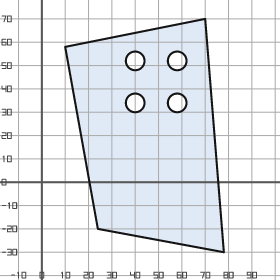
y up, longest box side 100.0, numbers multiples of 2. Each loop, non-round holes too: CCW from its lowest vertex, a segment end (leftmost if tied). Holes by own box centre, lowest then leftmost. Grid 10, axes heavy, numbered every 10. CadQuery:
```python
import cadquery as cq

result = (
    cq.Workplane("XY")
    .moveTo(78.0, -30.0)
    .lineTo(70.0, 70.0)
    .lineTo(10.0, 58.0)
    .lineTo(24.0, -20.0)
    .close()
    .moveTo(40.0, 34.0)
    .circle(4.0)
    .moveTo(58.0, 34.0)
    .circle(4.0)
    .moveTo(40.0, 52.0)
    .circle(4.0)
    .moveTo(58.0, 52.0)
    .circle(4.0)
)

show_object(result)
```